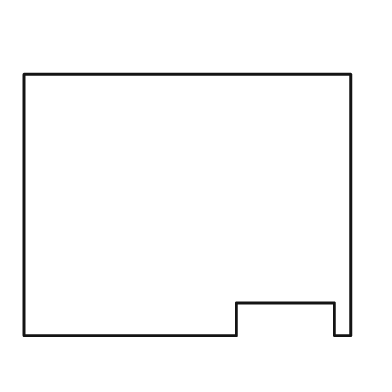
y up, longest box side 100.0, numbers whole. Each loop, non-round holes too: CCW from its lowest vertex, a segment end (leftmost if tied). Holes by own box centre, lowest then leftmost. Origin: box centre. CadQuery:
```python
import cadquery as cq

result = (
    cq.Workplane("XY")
    .moveTo(-50.0, -40.0)
    .lineTo(15.0, -40.0)
    .lineTo(15.0, -30.0)
    .lineTo(45.0, -30.0)
    .lineTo(45.0, -40.0)
    .lineTo(50.0, -40.0)
    .lineTo(50.0, 40.0)
    .lineTo(-50.0, 40.0)
    .close()
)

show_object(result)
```